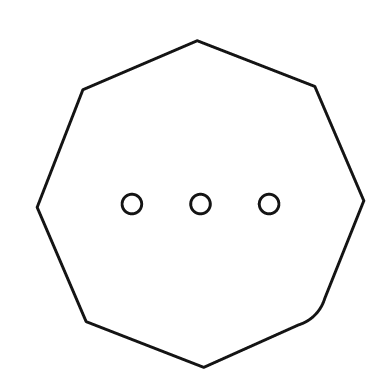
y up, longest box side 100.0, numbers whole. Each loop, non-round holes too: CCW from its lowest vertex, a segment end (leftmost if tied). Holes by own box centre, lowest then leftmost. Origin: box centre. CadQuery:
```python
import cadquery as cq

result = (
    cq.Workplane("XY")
    .moveTo(1.0, -50.0)
    .lineTo(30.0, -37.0)
    .threePointArc((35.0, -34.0), (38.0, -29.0))
    .lineTo(50.0, 1.0)
    .lineTo(35.0, 36.0)
    .lineTo(-1.0, 50.0)
    .lineTo(-36.0, 35.0)
    .lineTo(-50.0, -1.0)
    .lineTo(-35.0, -36.0)
    .close()
    .moveTo(-21.0, 0.0)
    .circle(3.0)
    .moveTo(0.0, 0.0)
    .circle(3.0)
    .moveTo(21.0, 0.0)
    .circle(3.0)
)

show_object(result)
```